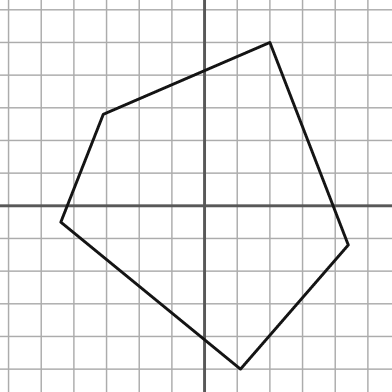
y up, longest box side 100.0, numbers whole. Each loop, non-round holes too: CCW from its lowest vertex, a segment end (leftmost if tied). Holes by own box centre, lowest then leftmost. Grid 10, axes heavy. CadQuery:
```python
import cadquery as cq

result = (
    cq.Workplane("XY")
    .moveTo(11.0, -50.0)
    .lineTo(44.0, -12.0)
    .lineTo(20.0, 50.0)
    .lineTo(-31.0, 28.0)
    .lineTo(-44.0, -5.0)
    .close()
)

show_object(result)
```